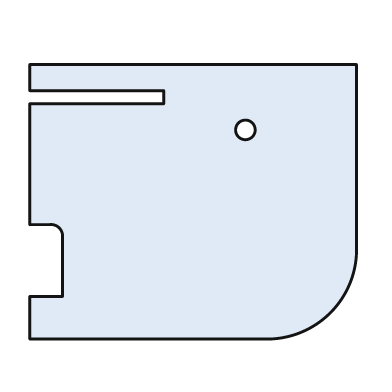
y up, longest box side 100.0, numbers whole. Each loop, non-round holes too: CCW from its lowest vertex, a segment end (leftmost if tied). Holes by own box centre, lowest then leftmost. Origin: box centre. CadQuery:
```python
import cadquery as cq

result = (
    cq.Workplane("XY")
    .moveTo(-50.0, -42.0)
    .lineTo(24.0, -42.0)
    .threePointArc((42.0, -34.0), (50.0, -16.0))
    .lineTo(50.0, 42.0)
    .lineTo(-50.0, 42.0)
    .lineTo(-50.0, 34.0)
    .lineTo(-9.0, 34.0)
    .lineTo(-9.0, 30.0)
    .lineTo(-50.0, 30.0)
    .lineTo(-50.0, -7.0)
    .lineTo(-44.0, -7.0)
    .threePointArc((-41.0, -8.0), (-40.0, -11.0))
    .lineTo(-40.0, -29.0)
    .lineTo(-50.0, -29.0)
    .close()
    .moveTo(16.0, 22.0)
    .circle(3.0)
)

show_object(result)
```